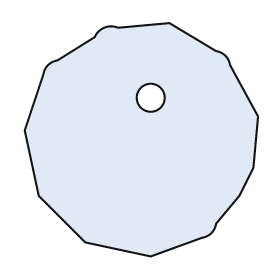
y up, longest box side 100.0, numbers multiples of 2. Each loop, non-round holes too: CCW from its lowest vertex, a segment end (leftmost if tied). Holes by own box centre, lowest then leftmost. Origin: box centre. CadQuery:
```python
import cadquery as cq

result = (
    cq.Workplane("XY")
    .moveTo(4.0, -50.0)
    .lineTo(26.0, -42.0)
    .threePointArc((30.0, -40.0), (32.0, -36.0))
    .lineTo(42.0, -24.0)
    .lineTo(48.0, -12.0)
    .lineTo(50.0, 10.0)
    .lineTo(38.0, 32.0)
    .threePointArc((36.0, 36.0), (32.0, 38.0))
    .lineTo(12.0, 50.0)
    .lineTo(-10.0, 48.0)
    .threePointArc((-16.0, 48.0), (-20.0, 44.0))
    .lineTo(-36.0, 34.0)
    .threePointArc((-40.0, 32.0), (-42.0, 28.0))
    .lineTo(-50.0, 4.0)
    .lineTo(-44.0, -24.0)
    .lineTo(-24.0, -44.0)
    .close()
    .moveTo(4.0, 18.0)
    .circle(6.0)
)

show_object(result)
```